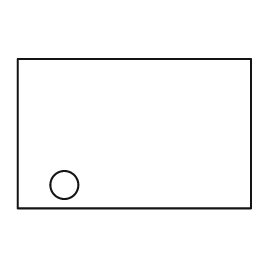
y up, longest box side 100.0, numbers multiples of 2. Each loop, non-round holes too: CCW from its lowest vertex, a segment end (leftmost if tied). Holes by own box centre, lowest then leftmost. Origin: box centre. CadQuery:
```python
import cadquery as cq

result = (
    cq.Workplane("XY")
    .moveTo(-50.0, -32.0)
    .lineTo(50.0, -32.0)
    .lineTo(50.0, 32.0)
    .lineTo(-50.0, 32.0)
    .close()
    .moveTo(-30.0, -22.0)
    .circle(6.0)
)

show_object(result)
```